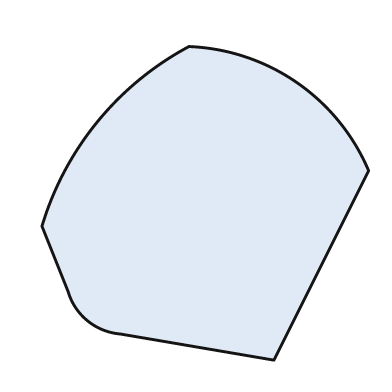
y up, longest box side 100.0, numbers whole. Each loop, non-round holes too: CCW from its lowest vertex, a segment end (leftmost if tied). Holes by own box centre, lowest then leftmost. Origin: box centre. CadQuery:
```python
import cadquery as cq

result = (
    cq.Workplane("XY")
    .moveTo(21.0, -48.0)
    .lineTo(50.0, 10.0)
    .threePointArc((28.0, 37.0), (-5.0, 48.0))
    .threePointArc((-33.0, 25.0), (-50.0, -7.0))
    .lineTo(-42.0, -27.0)
    .threePointArc((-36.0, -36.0), (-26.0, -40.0))
    .close()
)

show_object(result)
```